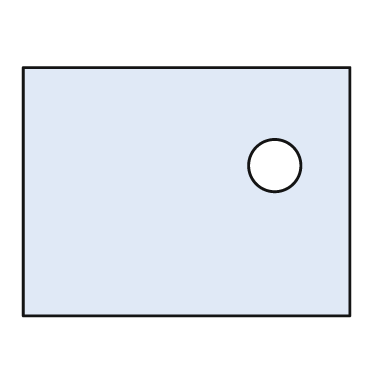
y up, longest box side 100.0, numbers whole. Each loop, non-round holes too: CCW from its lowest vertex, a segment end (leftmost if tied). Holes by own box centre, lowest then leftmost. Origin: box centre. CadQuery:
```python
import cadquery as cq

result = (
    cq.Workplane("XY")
    .moveTo(-50.0, -38.0)
    .lineTo(50.0, -38.0)
    .lineTo(50.0, 38.0)
    .lineTo(-50.0, 38.0)
    .close()
    .moveTo(27.0, 8.0)
    .circle(8.0)
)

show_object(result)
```